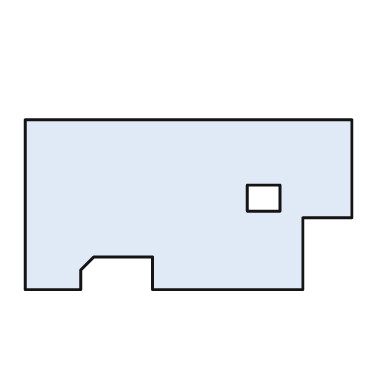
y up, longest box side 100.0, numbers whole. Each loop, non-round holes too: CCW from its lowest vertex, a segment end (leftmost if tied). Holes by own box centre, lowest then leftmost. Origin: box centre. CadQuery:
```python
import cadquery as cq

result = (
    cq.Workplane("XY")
    .moveTo(-50.0, -26.0)
    .lineTo(-33.0, -26.0)
    .lineTo(-33.0, -20.0)
    .lineTo(-29.0, -16.0)
    .lineTo(-11.0, -16.0)
    .lineTo(-11.0, -26.0)
    .lineTo(35.0, -26.0)
    .lineTo(35.0, -4.0)
    .lineTo(50.0, -4.0)
    .lineTo(50.0, 26.0)
    .lineTo(-50.0, 26.0)
    .close()
    .moveTo(18.0, -2.0)
    .lineTo(28.0, -2.0)
    .lineTo(28.0, 6.0)
    .lineTo(18.0, 6.0)
    .close()
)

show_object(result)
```